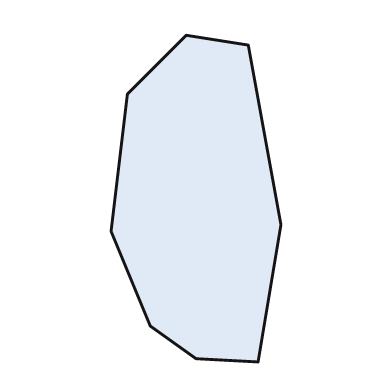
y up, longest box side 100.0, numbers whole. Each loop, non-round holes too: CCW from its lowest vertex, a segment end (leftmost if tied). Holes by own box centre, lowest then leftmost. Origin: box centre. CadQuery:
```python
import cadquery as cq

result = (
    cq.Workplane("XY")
    .moveTo(19.0, -50.0)
    .lineTo(26.0, -8.0)
    .lineTo(16.0, 47.0)
    .lineTo(-3.0, 50.0)
    .lineTo(-21.0, 32.0)
    .lineTo(-26.0, -10.0)
    .lineTo(-14.0, -39.0)
    .lineTo(0.0, -49.0)
    .close()
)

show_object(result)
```